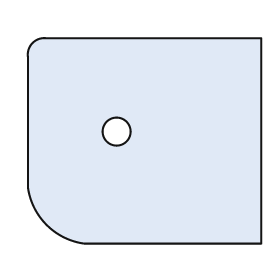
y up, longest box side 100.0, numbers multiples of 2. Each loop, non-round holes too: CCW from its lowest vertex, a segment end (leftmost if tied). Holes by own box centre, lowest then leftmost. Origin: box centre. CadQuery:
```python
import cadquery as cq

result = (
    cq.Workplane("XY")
    .moveTo(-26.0, -44.0)
    .lineTo(50.0, -44.0)
    .lineTo(50.0, 44.0)
    .lineTo(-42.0, 44.0)
    .threePointArc((-48.0, 42.0), (-50.0, 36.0))
    .lineTo(-50.0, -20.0)
    .threePointArc((-42.0, -36.0), (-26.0, -44.0))
    .close()
    .moveTo(-12.0, 4.0)
    .circle(6.0)
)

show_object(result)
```